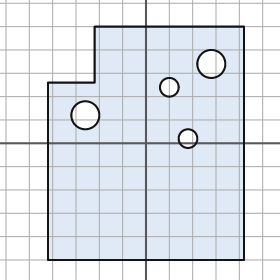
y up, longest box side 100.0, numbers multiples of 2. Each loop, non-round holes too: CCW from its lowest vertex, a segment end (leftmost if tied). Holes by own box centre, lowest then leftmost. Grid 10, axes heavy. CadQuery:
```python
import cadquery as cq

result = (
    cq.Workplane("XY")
    .moveTo(-42.0, -50.0)
    .lineTo(42.0, -50.0)
    .lineTo(42.0, 50.0)
    .lineTo(-22.0, 50.0)
    .lineTo(-22.0, 26.0)
    .lineTo(-42.0, 26.0)
    .close()
    .moveTo(18.0, 2.0)
    .circle(4.0)
    .moveTo(-26.0, 12.0)
    .circle(6.0)
    .moveTo(10.0, 24.0)
    .circle(4.0)
    .moveTo(28.0, 34.0)
    .circle(6.0)
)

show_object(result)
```